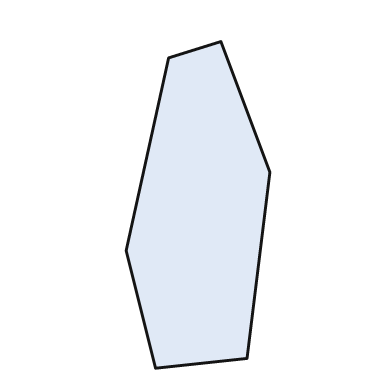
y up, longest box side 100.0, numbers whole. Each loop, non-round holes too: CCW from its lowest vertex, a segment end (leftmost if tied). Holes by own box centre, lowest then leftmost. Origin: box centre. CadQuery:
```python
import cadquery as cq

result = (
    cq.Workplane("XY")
    .moveTo(-13.0, -50.0)
    .lineTo(15.0, -47.0)
    .lineTo(22.0, 10.0)
    .lineTo(7.0, 50.0)
    .lineTo(-9.0, 45.0)
    .lineTo(-22.0, -14.0)
    .close()
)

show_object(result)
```